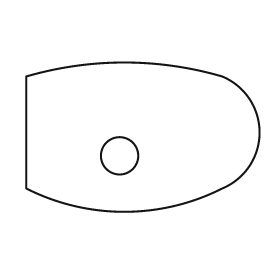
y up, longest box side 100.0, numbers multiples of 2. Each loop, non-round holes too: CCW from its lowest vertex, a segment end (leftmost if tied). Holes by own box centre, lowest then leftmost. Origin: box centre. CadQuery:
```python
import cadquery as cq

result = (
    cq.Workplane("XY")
    .moveTo(-50.0, -22.0)
    .threePointArc((-8.0, -32.0), (34.0, -22.0))
    .threePointArc((50.0, 2.0), (34.0, 26.0))
    .threePointArc((-8.0, 32.0), (-50.0, 26.0))
    .close()
    .moveTo(-10.0, -8.0)
    .circle(8.0)
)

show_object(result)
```